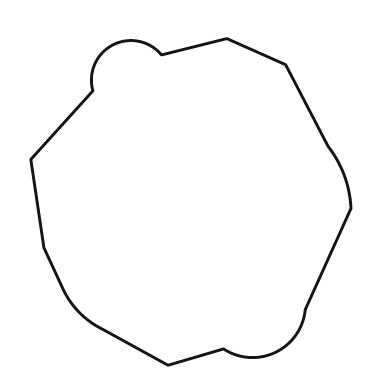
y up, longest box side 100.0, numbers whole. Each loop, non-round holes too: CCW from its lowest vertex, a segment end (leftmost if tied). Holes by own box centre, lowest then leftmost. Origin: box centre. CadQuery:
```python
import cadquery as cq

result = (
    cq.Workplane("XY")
    .moveTo(-7.0, -50.0)
    .lineTo(10.0, -45.0)
    .threePointArc((26.0, -46.0), (35.0, -33.0))
    .lineTo(49.0, -2.0)
    .threePointArc((47.0, 8.0), (42.0, 17.0))
    .lineTo(29.0, 42.0)
    .lineTo(11.0, 50.0)
    .lineTo(-9.0, 45.0)
    .threePointArc((-24.0, 48.0), (-30.0, 34.0))
    .lineTo(-49.0, 13.0)
    .lineTo(-45.0, -14.0)
    .lineTo(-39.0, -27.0)
    .threePointArc((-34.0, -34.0), (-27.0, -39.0))
    .close()
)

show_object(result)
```